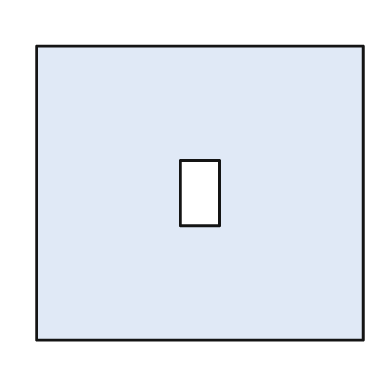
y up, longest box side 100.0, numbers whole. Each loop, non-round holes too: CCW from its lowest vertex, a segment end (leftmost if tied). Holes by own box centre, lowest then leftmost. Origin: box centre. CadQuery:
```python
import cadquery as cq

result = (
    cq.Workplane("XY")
    .moveTo(-50.0, -45.0)
    .lineTo(50.0, -45.0)
    .lineTo(50.0, 45.0)
    .lineTo(-50.0, 45.0)
    .close()
    .moveTo(-6.0, -10.0)
    .lineTo(6.0, -10.0)
    .lineTo(6.0, 10.0)
    .lineTo(-6.0, 10.0)
    .close()
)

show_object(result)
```